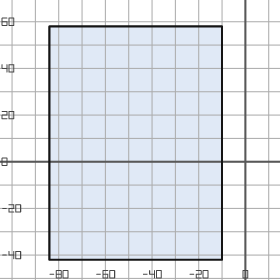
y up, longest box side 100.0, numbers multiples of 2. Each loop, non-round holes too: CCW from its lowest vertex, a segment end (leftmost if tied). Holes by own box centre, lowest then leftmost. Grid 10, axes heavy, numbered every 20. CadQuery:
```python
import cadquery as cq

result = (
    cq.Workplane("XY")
    .moveTo(-84.0, -42.0)
    .lineTo(-10.0, -42.0)
    .lineTo(-10.0, 58.0)
    .lineTo(-84.0, 58.0)
    .close()
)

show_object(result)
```